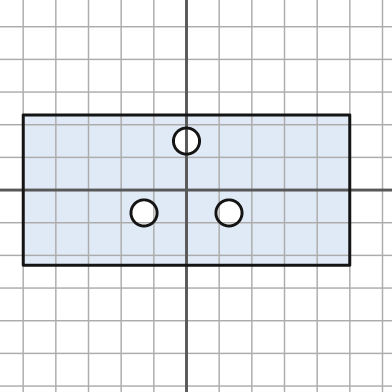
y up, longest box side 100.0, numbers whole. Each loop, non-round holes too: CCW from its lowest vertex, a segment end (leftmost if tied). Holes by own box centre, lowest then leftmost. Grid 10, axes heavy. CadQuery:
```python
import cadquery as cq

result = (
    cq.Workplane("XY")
    .moveTo(-50.0, -23.0)
    .lineTo(50.0, -23.0)
    .lineTo(50.0, 23.0)
    .lineTo(-50.0, 23.0)
    .close()
    .moveTo(-13.0, -7.0)
    .circle(4.0)
    .moveTo(13.0, -7.0)
    .circle(4.0)
    .moveTo(0.0, 15.0)
    .circle(4.0)
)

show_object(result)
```